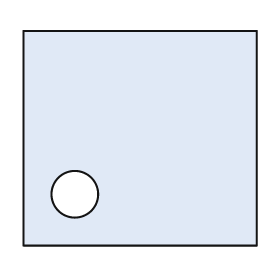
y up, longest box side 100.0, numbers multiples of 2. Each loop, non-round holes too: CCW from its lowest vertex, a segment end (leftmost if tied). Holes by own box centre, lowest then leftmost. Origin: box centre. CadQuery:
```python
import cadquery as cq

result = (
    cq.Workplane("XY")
    .moveTo(-50.0, -46.0)
    .lineTo(50.0, -46.0)
    .lineTo(50.0, 46.0)
    .lineTo(-50.0, 46.0)
    .close()
    .moveTo(-28.0, -24.0)
    .circle(10.0)
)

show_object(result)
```